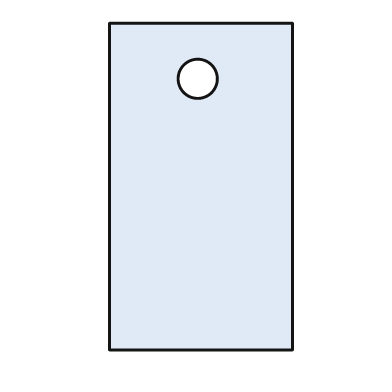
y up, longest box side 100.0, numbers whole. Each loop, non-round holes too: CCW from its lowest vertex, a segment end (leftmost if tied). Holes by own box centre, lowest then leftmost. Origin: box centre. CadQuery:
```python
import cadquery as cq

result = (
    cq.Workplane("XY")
    .moveTo(-28.0, -50.0)
    .lineTo(28.0, -50.0)
    .lineTo(28.0, 50.0)
    .lineTo(-28.0, 50.0)
    .close()
    .moveTo(-1.0, 33.0)
    .circle(6.0)
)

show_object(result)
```